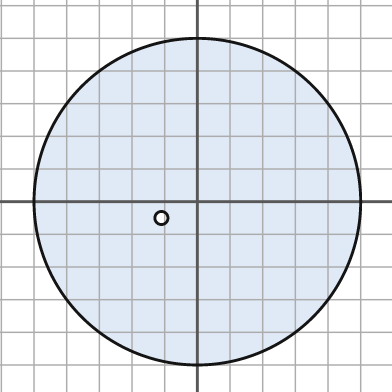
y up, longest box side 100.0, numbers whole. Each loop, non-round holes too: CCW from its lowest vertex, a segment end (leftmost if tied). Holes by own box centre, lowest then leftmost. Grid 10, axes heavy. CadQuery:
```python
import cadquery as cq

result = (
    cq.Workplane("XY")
    .moveTo(0.0, 0.0)
    .circle(50.0)
    .moveTo(-11.0, -5.0)
    .circle(2.0)
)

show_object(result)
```